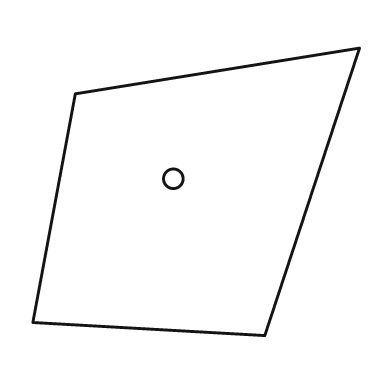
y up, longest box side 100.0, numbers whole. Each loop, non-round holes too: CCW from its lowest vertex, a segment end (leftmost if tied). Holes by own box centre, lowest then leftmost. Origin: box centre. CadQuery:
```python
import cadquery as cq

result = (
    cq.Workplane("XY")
    .moveTo(21.0, -44.0)
    .lineTo(50.0, 44.0)
    .lineTo(-37.0, 30.0)
    .lineTo(-50.0, -40.0)
    .close()
    .moveTo(-7.0, 4.0)
    .circle(3.0)
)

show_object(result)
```